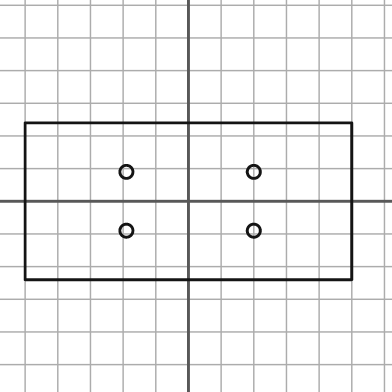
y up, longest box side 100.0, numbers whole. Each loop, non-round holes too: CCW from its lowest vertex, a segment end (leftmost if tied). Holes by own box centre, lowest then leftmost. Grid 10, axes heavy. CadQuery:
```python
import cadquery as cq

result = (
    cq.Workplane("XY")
    .moveTo(-50.0, -24.0)
    .lineTo(50.0, -24.0)
    .lineTo(50.0, 24.0)
    .lineTo(-50.0, 24.0)
    .close()
    .moveTo(-19.0, -9.0)
    .circle(2.0)
    .moveTo(20.0, -9.0)
    .circle(2.0)
    .moveTo(-19.0, 9.0)
    .circle(2.0)
    .moveTo(20.0, 9.0)
    .circle(2.0)
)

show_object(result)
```